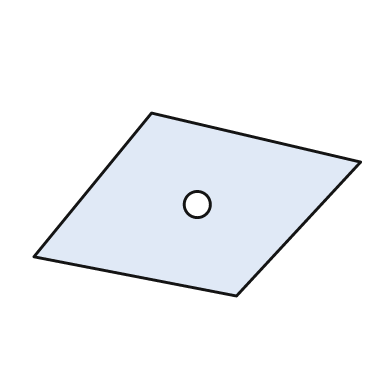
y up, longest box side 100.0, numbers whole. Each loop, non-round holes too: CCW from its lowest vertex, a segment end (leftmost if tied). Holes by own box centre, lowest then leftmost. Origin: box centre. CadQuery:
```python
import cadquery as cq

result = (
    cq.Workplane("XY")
    .moveTo(12.0, -28.0)
    .lineTo(50.0, 13.0)
    .lineTo(-14.0, 28.0)
    .lineTo(-50.0, -16.0)
    .close()
    .moveTo(0.0, 0.0)
    .circle(4.0)
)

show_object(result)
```